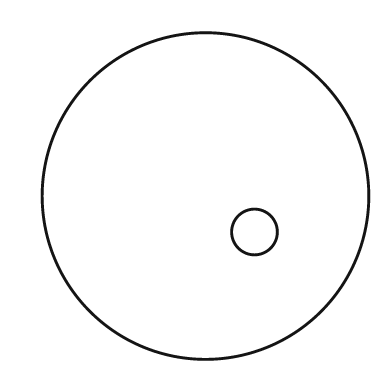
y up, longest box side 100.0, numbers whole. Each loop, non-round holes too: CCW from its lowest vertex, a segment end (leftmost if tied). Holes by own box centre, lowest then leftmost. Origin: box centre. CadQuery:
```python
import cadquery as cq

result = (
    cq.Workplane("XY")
    .moveTo(0.0, 0.0)
    .circle(50.0)
    .moveTo(15.0, -11.0)
    .circle(7.0)
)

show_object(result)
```